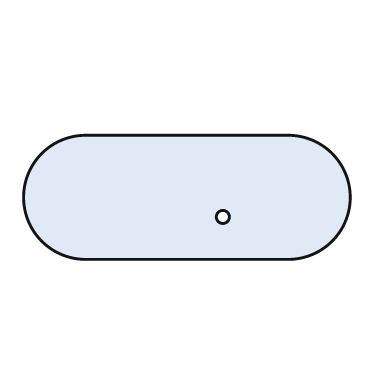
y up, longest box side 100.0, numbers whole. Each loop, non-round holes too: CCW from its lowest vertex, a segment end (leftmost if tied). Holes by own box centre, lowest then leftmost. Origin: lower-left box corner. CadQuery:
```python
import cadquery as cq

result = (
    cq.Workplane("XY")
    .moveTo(19.0, 0.0)
    .lineTo(81.0, 0.0)
    .threePointArc((100.0, 19.0), (81.0, 38.0))
    .lineTo(19.0, 38.0)
    .threePointArc((0.0, 19.0), (19.0, 0.0))
    .close()
    .moveTo(61.0, 13.0)
    .circle(2.0)
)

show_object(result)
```